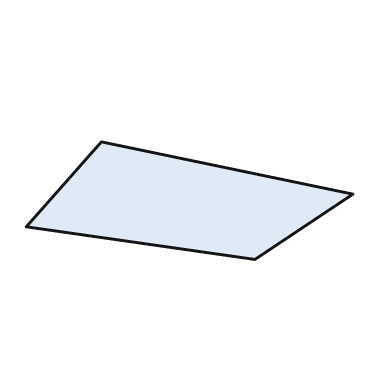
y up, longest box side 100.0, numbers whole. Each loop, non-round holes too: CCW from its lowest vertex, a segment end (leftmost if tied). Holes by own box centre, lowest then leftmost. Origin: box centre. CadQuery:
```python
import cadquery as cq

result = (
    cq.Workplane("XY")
    .moveTo(20.0, -18.0)
    .lineTo(50.0, 2.0)
    .lineTo(-27.0, 18.0)
    .lineTo(-50.0, -8.0)
    .close()
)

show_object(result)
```